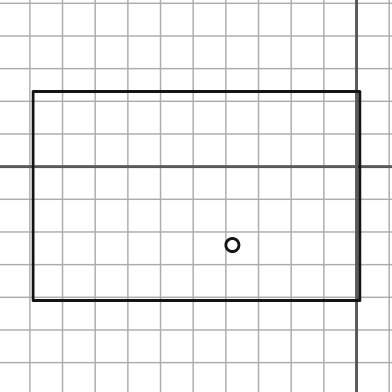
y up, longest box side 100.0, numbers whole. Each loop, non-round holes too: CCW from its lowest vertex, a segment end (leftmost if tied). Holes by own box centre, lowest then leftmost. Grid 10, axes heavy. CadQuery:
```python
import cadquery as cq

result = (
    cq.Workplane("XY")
    .moveTo(-99.0, -41.0)
    .lineTo(1.0, -41.0)
    .lineTo(1.0, 23.0)
    .lineTo(-99.0, 23.0)
    .close()
    .moveTo(-38.0, -24.0)
    .circle(2.0)
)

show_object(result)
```